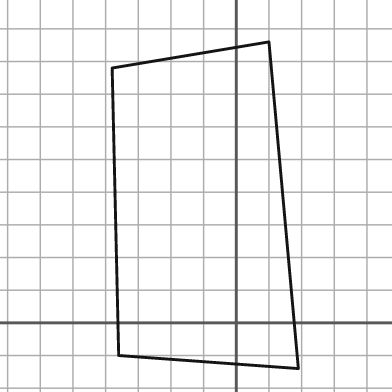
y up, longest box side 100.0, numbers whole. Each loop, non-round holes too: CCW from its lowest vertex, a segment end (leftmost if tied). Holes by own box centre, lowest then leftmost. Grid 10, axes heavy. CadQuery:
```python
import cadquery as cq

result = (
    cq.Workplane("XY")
    .moveTo(19.0, -14.0)
    .lineTo(10.0, 86.0)
    .lineTo(-38.0, 78.0)
    .lineTo(-36.0, -10.0)
    .close()
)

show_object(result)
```